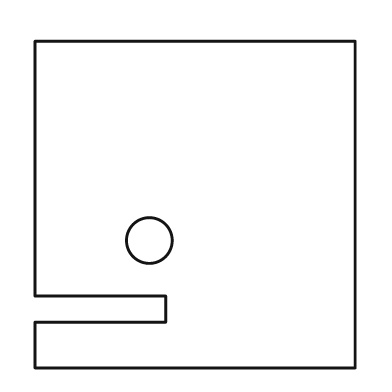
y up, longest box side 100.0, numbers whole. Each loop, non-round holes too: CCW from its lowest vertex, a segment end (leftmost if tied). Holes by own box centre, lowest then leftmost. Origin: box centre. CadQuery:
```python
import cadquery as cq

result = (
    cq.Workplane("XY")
    .moveTo(-49.0, -50.0)
    .lineTo(49.0, -50.0)
    .lineTo(49.0, 50.0)
    .lineTo(-49.0, 50.0)
    .lineTo(-49.0, -28.0)
    .lineTo(-9.0, -28.0)
    .lineTo(-9.0, -36.0)
    .lineTo(-49.0, -36.0)
    .close()
    .moveTo(-14.0, -11.0)
    .circle(7.0)
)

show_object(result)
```